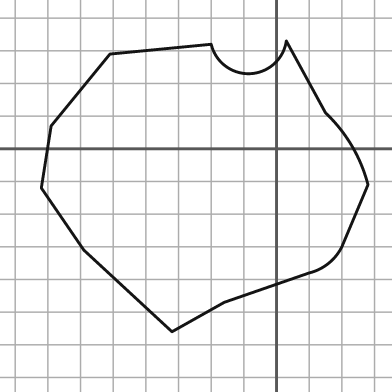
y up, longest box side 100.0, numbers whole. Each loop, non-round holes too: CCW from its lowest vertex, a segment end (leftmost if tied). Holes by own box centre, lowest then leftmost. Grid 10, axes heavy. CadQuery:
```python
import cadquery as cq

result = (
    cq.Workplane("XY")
    .moveTo(-32.0, -56.0)
    .lineTo(-16.0, -47.0)
    .lineTo(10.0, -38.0)
    .threePointArc((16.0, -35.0), (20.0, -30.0))
    .lineTo(28.0, -11.0)
    .threePointArc((23.0, 1.0), (15.0, 11.0))
    .lineTo(3.0, 33.0)
    .threePointArc((-8.0, 23.0), (-20.0, 32.0))
    .lineTo(-51.0, 29.0)
    .lineTo(-69.0, 7.0)
    .lineTo(-72.0, -12.0)
    .lineTo(-59.0, -31.0)
    .close()
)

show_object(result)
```